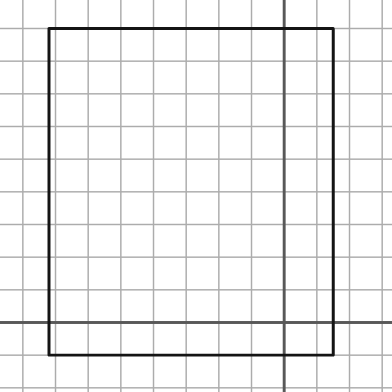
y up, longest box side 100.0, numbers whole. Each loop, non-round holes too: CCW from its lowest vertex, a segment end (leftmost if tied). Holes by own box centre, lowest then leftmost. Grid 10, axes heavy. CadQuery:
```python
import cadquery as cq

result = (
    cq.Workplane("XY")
    .moveTo(-72.0, -10.0)
    .lineTo(15.0, -10.0)
    .lineTo(15.0, 90.0)
    .lineTo(-72.0, 90.0)
    .close()
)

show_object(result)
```